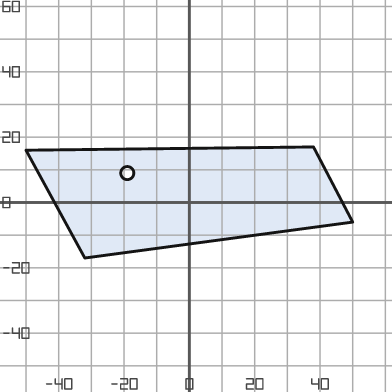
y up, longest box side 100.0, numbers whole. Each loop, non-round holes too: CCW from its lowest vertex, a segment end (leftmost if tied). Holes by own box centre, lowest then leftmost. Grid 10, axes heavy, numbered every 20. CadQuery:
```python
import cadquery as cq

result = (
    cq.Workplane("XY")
    .moveTo(-32.0, -17.0)
    .lineTo(50.0, -6.0)
    .lineTo(38.0, 17.0)
    .lineTo(-50.0, 16.0)
    .close()
    .moveTo(-19.0, 9.0)
    .circle(2.0)
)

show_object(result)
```